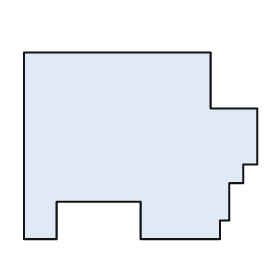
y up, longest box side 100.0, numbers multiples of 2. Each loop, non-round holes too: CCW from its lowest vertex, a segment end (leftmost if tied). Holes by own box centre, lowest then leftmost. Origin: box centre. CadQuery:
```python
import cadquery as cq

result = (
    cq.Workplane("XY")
    .moveTo(-50.0, -40.0)
    .lineTo(-36.0, -40.0)
    .lineTo(-36.0, -24.0)
    .lineTo(0.0, -24.0)
    .lineTo(0.0, -40.0)
    .lineTo(34.0, -40.0)
    .lineTo(34.0, -32.0)
    .lineTo(38.0, -32.0)
    .lineTo(38.0, -16.0)
    .lineTo(44.0, -16.0)
    .lineTo(44.0, -8.0)
    .lineTo(50.0, -8.0)
    .lineTo(50.0, 16.0)
    .lineTo(30.0, 16.0)
    .lineTo(30.0, 40.0)
    .lineTo(-50.0, 40.0)
    .close()
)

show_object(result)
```